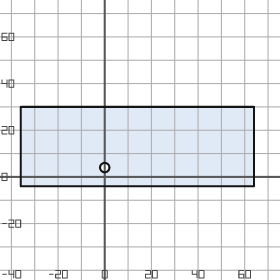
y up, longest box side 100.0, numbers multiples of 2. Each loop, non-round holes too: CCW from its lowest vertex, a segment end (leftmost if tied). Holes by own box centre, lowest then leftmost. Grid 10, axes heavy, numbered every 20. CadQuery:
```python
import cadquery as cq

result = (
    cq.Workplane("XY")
    .moveTo(-36.0, -4.0)
    .lineTo(64.0, -4.0)
    .lineTo(64.0, 30.0)
    .lineTo(-36.0, 30.0)
    .close()
    .moveTo(0.0, 4.0)
    .circle(2.0)
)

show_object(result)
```